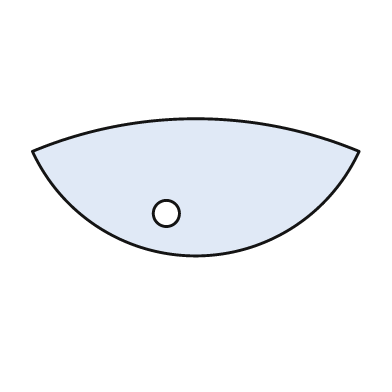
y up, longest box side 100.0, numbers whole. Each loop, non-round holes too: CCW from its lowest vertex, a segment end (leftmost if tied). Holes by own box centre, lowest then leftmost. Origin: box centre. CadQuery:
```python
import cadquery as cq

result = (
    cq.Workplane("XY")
    .moveTo(-50.0, 11.0)
    .threePointArc((0.0, -21.0), (50.0, 11.0))
    .threePointArc((0.0, 21.0), (-50.0, 11.0))
    .close()
    .moveTo(-9.0, -8.0)
    .circle(4.0)
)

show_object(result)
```